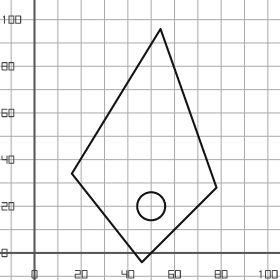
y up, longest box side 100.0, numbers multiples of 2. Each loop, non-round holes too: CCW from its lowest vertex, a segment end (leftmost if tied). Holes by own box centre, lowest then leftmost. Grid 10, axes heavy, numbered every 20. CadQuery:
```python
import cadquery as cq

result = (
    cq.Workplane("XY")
    .moveTo(46.0, -4.0)
    .lineTo(78.0, 28.0)
    .lineTo(54.0, 96.0)
    .lineTo(16.0, 34.0)
    .close()
    .moveTo(50.0, 20.0)
    .circle(6.0)
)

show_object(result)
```